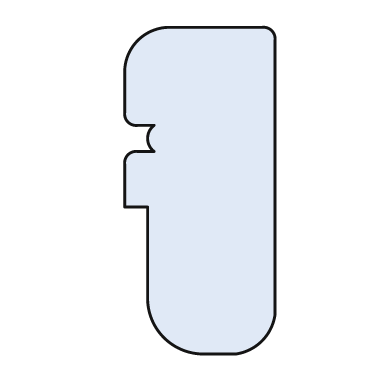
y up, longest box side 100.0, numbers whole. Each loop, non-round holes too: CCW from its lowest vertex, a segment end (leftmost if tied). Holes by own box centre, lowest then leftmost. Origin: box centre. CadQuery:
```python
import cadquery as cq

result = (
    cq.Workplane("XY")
    .moveTo(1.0, -50.0)
    .lineTo(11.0, -50.0)
    .threePointArc((19.0, -46.0), (23.0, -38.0))
    .lineTo(23.0, 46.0)
    .threePointArc((22.0, 49.0), (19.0, 50.0))
    .lineTo(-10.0, 50.0)
    .threePointArc((-19.0, 46.0), (-23.0, 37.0))
    .lineTo(-23.0, 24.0)
    .threePointArc((-22.0, 21.0), (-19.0, 20.0))
    .lineTo(-14.0, 20.0)
    .threePointArc((-16.0, 16.0), (-14.0, 12.0))
    .lineTo(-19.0, 12.0)
    .threePointArc((-22.0, 11.0), (-23.0, 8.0))
    .lineTo(-23.0, -5.0)
    .lineTo(-16.0, -5.0)
    .lineTo(-16.0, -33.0)
    .threePointArc((-11.0, -45.0), (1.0, -50.0))
    .close()
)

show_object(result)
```